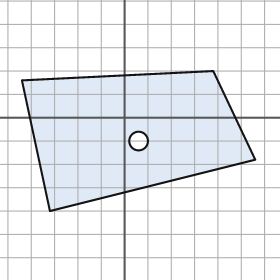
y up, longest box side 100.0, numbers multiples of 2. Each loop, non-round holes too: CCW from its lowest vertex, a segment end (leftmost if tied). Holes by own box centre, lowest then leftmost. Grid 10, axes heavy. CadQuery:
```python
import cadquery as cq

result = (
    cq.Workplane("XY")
    .moveTo(-32.0, -40.0)
    .lineTo(56.0, -18.0)
    .lineTo(38.0, 20.0)
    .lineTo(-44.0, 16.0)
    .close()
    .moveTo(6.0, -10.0)
    .circle(4.0)
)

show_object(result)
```